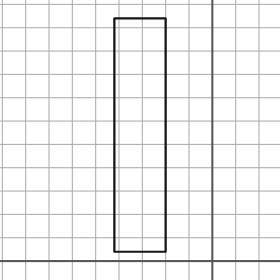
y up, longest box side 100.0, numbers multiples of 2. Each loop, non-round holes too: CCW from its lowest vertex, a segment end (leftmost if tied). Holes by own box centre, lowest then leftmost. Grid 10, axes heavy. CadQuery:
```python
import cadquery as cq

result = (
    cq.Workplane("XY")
    .moveTo(-42.0, 4.0)
    .lineTo(-20.0, 4.0)
    .lineTo(-20.0, 104.0)
    .lineTo(-42.0, 104.0)
    .close()
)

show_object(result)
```